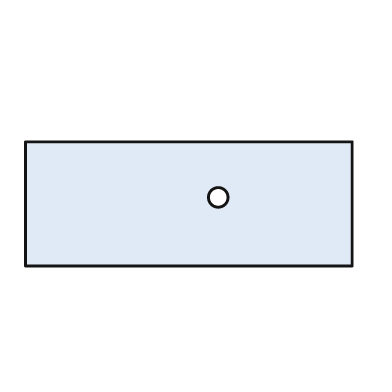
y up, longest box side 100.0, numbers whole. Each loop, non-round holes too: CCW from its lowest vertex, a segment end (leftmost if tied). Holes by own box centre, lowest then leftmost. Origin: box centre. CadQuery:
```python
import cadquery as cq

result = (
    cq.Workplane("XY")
    .moveTo(-50.0, -19.0)
    .lineTo(50.0, -19.0)
    .lineTo(50.0, 19.0)
    .lineTo(-50.0, 19.0)
    .close()
    .moveTo(9.0, 2.0)
    .circle(3.0)
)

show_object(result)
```